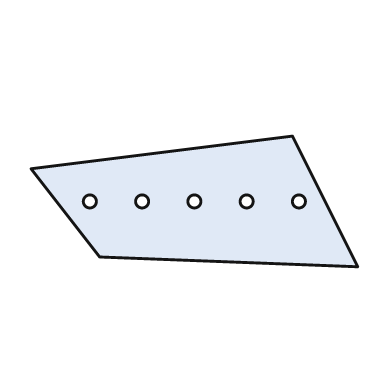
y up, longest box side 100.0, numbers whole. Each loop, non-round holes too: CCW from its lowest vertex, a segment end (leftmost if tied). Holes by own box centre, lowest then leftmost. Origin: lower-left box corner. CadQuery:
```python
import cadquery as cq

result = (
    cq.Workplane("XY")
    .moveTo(100.0, 0.0)
    .lineTo(80.0, 40.0)
    .lineTo(0.0, 30.0)
    .lineTo(21.0, 3.0)
    .close()
    .moveTo(18.0, 20.0)
    .circle(2.0)
    .moveTo(34.0, 20.0)
    .circle(2.0)
    .moveTo(50.0, 20.0)
    .circle(2.0)
    .moveTo(66.0, 20.0)
    .circle(2.0)
    .moveTo(82.0, 20.0)
    .circle(2.0)
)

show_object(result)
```